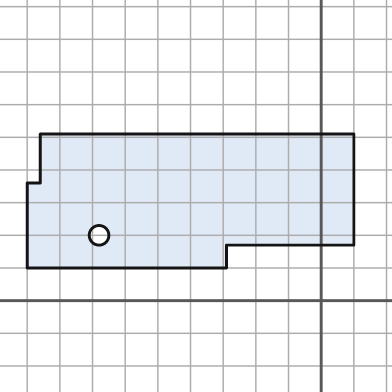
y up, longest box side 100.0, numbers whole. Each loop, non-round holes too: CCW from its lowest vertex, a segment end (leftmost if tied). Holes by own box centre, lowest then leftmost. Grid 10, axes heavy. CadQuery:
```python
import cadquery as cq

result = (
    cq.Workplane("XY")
    .moveTo(-90.0, 10.0)
    .lineTo(-29.0, 10.0)
    .lineTo(-29.0, 17.0)
    .lineTo(10.0, 17.0)
    .lineTo(10.0, 51.0)
    .lineTo(-86.0, 51.0)
    .lineTo(-86.0, 36.0)
    .lineTo(-90.0, 36.0)
    .close()
    .moveTo(-68.0, 20.0)
    .circle(3.0)
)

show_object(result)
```